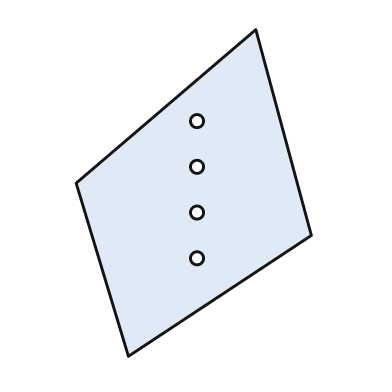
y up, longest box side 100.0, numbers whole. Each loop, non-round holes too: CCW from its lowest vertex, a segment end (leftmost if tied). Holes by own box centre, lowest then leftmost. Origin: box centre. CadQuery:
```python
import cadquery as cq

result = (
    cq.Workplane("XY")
    .moveTo(-20.0, -50.0)
    .lineTo(36.0, -13.0)
    .lineTo(19.0, 50.0)
    .lineTo(-36.0, 3.0)
    .close()
    .moveTo(1.0, -20.0)
    .circle(2.0)
    .moveTo(1.0, -6.0)
    .circle(2.0)
    .moveTo(1.0, 8.0)
    .circle(2.0)
    .moveTo(1.0, 22.0)
    .circle(2.0)
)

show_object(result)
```